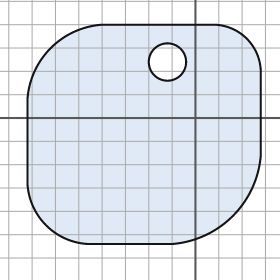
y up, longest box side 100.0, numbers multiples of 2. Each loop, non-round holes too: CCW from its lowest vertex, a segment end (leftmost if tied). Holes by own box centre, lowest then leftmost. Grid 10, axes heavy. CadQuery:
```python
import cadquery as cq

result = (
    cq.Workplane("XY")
    .moveTo(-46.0, -54.0)
    .lineTo(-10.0, -54.0)
    .threePointArc((16.0, -42.0), (28.0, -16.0))
    .lineTo(28.0, 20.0)
    .threePointArc((22.0, 34.0), (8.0, 40.0))
    .lineTo(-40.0, 40.0)
    .threePointArc((-62.0, 30.0), (-72.0, 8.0))
    .lineTo(-72.0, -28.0)
    .threePointArc((-64.0, -46.0), (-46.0, -54.0))
    .close()
    .moveTo(-12.0, 24.0)
    .circle(8.0)
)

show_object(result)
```